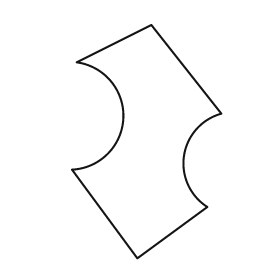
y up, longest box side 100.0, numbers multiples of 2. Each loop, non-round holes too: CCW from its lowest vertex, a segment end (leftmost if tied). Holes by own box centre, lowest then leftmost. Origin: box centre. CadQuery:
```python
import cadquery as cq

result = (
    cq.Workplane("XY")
    .moveTo(-4.0, -50.0)
    .lineTo(26.0, -28.0)
    .threePointArc((16.0, -6.0), (32.0, 12.0))
    .lineTo(2.0, 50.0)
    .lineTo(-30.0, 34.0)
    .threePointArc((-10.0, 10.0), (-32.0, -12.0))
    .close()
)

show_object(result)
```